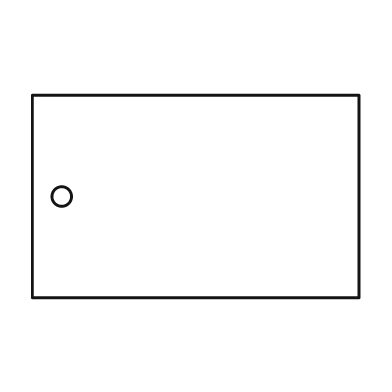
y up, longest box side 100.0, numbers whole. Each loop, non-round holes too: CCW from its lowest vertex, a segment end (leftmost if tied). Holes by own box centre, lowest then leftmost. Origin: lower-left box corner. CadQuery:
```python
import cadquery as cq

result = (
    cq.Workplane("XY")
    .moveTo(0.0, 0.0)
    .lineTo(100.0, 0.0)
    .lineTo(100.0, 62.0)
    .lineTo(0.0, 62.0)
    .close()
    .moveTo(9.0, 31.0)
    .circle(3.0)
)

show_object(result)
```